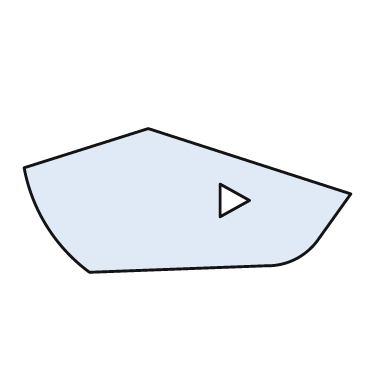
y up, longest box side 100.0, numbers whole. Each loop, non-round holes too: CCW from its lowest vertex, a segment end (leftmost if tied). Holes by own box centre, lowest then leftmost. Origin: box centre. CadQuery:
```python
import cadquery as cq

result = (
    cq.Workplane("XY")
    .moveTo(-30.0, -22.0)
    .lineTo(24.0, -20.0)
    .threePointArc((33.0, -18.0), (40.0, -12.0))
    .lineTo(50.0, 2.0)
    .lineTo(-12.0, 22.0)
    .lineTo(-50.0, 10.0)
    .threePointArc((-43.0, -8.0), (-30.0, -22.0))
    .close()
    .moveTo(10.0, -5.0)
    .lineTo(19.0, 0.0)
    .lineTo(10.0, 5.0)
    .close()
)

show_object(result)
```